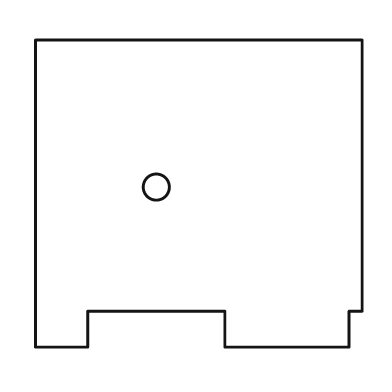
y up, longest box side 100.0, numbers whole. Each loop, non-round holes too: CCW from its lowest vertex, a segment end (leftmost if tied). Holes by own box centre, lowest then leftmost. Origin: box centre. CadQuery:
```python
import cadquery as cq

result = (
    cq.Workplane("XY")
    .moveTo(-50.0, -47.0)
    .lineTo(-34.0, -47.0)
    .lineTo(-34.0, -36.0)
    .lineTo(8.0, -36.0)
    .lineTo(8.0, -47.0)
    .lineTo(46.0, -47.0)
    .lineTo(46.0, -36.0)
    .lineTo(50.0, -36.0)
    .lineTo(50.0, 47.0)
    .lineTo(-50.0, 47.0)
    .close()
    .moveTo(-13.0, 2.0)
    .circle(4.0)
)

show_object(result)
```